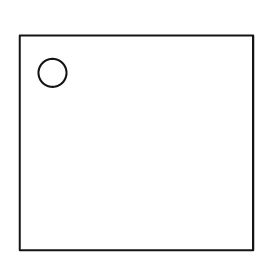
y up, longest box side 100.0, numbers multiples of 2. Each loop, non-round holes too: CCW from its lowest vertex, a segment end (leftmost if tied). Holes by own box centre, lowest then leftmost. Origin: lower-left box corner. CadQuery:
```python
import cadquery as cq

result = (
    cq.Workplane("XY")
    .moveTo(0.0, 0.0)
    .lineTo(100.0, 0.0)
    .lineTo(100.0, 92.0)
    .lineTo(0.0, 92.0)
    .close()
    .moveTo(14.0, 76.0)
    .circle(6.0)
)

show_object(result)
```